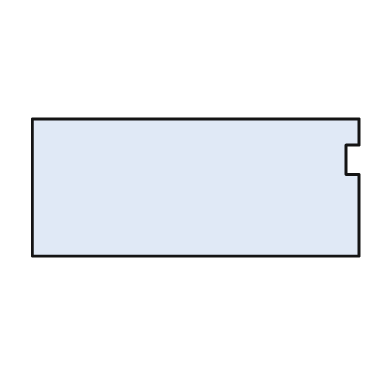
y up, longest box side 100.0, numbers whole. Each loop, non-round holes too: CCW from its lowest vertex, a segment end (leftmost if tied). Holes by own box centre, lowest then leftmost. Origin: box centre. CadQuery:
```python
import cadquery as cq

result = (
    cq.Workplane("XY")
    .moveTo(-50.0, -21.0)
    .lineTo(50.0, -21.0)
    .lineTo(50.0, 4.0)
    .lineTo(46.0, 4.0)
    .lineTo(46.0, 13.0)
    .lineTo(50.0, 13.0)
    .lineTo(50.0, 21.0)
    .lineTo(-50.0, 21.0)
    .close()
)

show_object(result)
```